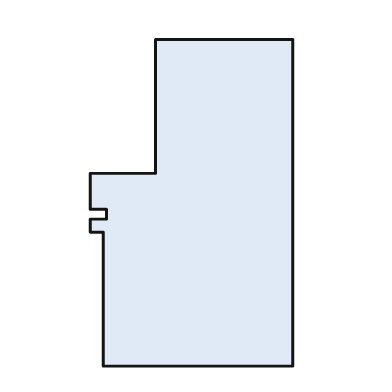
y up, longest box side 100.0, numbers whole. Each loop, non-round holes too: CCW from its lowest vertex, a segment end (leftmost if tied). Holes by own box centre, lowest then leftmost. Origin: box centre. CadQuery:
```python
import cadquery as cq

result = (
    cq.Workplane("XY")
    .moveTo(-27.0, -50.0)
    .lineTo(31.0, -50.0)
    .lineTo(31.0, 50.0)
    .lineTo(-11.0, 50.0)
    .lineTo(-11.0, 9.0)
    .lineTo(-31.0, 9.0)
    .lineTo(-31.0, -2.0)
    .lineTo(-26.0, -2.0)
    .lineTo(-26.0, -5.0)
    .lineTo(-31.0, -5.0)
    .lineTo(-31.0, -9.0)
    .lineTo(-27.0, -9.0)
    .close()
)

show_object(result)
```